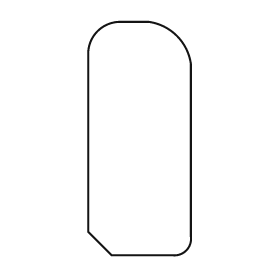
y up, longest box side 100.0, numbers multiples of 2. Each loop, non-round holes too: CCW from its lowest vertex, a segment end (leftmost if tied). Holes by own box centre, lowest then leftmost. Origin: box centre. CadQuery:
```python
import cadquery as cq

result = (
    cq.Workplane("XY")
    .moveTo(-12.0, -50.0)
    .lineTo(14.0, -50.0)
    .threePointArc((20.0, -48.0), (22.0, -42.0))
    .lineTo(22.0, 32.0)
    .threePointArc((16.0, 44.0), (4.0, 50.0))
    .lineTo(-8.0, 50.0)
    .threePointArc((-18.0, 46.0), (-22.0, 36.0))
    .lineTo(-22.0, -40.0)
    .close()
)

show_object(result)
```